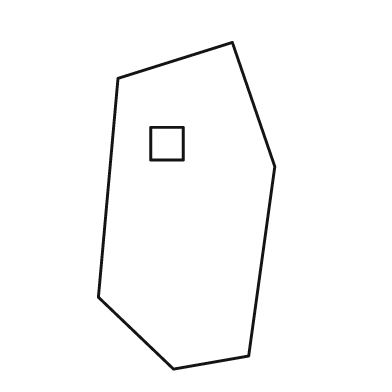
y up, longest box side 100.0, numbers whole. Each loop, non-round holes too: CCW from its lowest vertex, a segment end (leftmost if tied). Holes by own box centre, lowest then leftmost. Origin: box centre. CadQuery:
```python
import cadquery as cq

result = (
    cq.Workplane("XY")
    .moveTo(-4.0, -50.0)
    .lineTo(19.0, -46.0)
    .lineTo(27.0, 12.0)
    .lineTo(14.0, 50.0)
    .lineTo(-21.0, 39.0)
    .lineTo(-27.0, -28.0)
    .close()
    .moveTo(-11.0, 14.0)
    .lineTo(-1.0, 14.0)
    .lineTo(-1.0, 24.0)
    .lineTo(-11.0, 24.0)
    .close()
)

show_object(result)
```